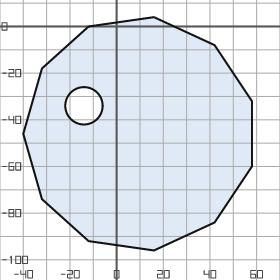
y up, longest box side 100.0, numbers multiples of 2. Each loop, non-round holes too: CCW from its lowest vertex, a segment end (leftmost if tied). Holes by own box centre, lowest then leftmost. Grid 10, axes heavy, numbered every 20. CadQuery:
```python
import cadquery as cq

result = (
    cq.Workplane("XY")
    .moveTo(16.0, -96.0)
    .lineTo(42.0, -84.0)
    .lineTo(58.0, -60.0)
    .lineTo(58.0, -32.0)
    .lineTo(42.0, -8.0)
    .lineTo(16.0, 4.0)
    .lineTo(-12.0, 0.0)
    .lineTo(-32.0, -18.0)
    .lineTo(-40.0, -46.0)
    .lineTo(-32.0, -74.0)
    .lineTo(-12.0, -92.0)
    .close()
    .moveTo(-14.0, -34.0)
    .circle(8.0)
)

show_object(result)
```